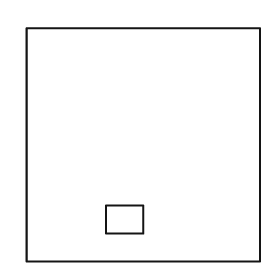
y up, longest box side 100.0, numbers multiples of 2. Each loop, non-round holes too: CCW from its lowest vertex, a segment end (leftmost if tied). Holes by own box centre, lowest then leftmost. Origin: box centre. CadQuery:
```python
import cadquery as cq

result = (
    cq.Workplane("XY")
    .moveTo(-50.0, -50.0)
    .lineTo(50.0, -50.0)
    .lineTo(50.0, 50.0)
    .lineTo(-50.0, 50.0)
    .close()
    .moveTo(-16.0, -38.0)
    .lineTo(0.0, -38.0)
    .lineTo(0.0, -26.0)
    .lineTo(-16.0, -26.0)
    .close()
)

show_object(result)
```